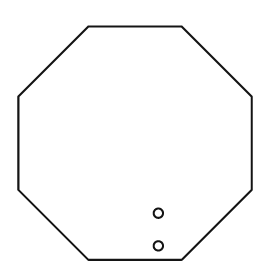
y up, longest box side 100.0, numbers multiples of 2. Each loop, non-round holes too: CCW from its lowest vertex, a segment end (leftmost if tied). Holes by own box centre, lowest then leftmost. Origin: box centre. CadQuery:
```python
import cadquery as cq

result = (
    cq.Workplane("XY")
    .moveTo(-20.0, -50.0)
    .lineTo(20.0, -50.0)
    .lineTo(50.0, -20.0)
    .lineTo(50.0, 20.0)
    .lineTo(20.0, 50.0)
    .lineTo(-20.0, 50.0)
    .lineTo(-50.0, 20.0)
    .lineTo(-50.0, -20.0)
    .close()
    .moveTo(10.0, -44.0)
    .circle(2.0)
    .moveTo(10.0, -30.0)
    .circle(2.0)
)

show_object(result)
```